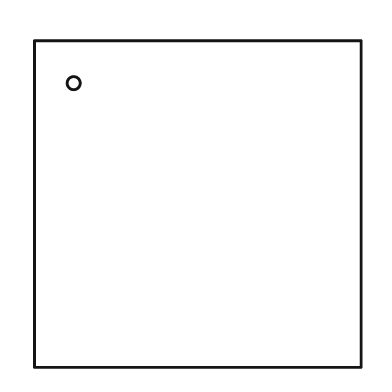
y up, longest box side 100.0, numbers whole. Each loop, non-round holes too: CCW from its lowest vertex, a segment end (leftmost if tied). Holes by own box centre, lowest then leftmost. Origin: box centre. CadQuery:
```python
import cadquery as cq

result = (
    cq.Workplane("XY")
    .moveTo(-50.0, -50.0)
    .lineTo(50.0, -50.0)
    .lineTo(50.0, 50.0)
    .lineTo(-50.0, 50.0)
    .close()
    .moveTo(-38.0, 37.0)
    .circle(2.0)
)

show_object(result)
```